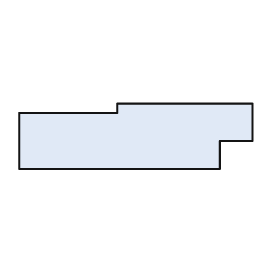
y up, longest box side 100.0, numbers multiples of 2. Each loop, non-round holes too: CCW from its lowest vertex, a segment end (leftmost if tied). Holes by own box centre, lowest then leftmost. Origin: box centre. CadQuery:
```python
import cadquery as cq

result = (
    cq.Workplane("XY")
    .moveTo(-50.0, -14.0)
    .lineTo(36.0, -14.0)
    .lineTo(36.0, -2.0)
    .lineTo(50.0, -2.0)
    .lineTo(50.0, 14.0)
    .lineTo(-8.0, 14.0)
    .lineTo(-8.0, 10.0)
    .lineTo(-50.0, 10.0)
    .close()
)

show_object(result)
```